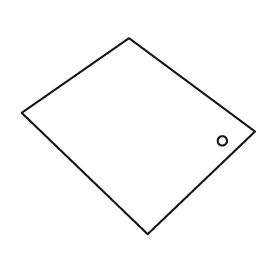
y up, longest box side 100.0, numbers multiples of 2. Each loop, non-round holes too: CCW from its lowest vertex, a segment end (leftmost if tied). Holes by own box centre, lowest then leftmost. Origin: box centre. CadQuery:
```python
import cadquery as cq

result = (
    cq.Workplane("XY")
    .moveTo(4.0, -42.0)
    .lineTo(50.0, 2.0)
    .lineTo(-4.0, 42.0)
    .lineTo(-50.0, 10.0)
    .close()
    .moveTo(36.0, -2.0)
    .circle(2.0)
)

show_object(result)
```